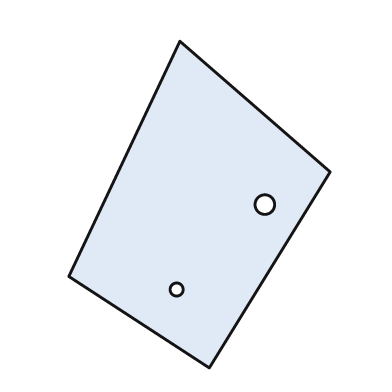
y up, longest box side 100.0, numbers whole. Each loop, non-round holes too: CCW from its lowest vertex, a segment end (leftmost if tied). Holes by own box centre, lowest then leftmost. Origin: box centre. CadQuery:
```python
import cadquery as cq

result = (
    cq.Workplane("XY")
    .moveTo(3.0, -50.0)
    .lineTo(40.0, 10.0)
    .lineTo(-6.0, 50.0)
    .lineTo(-40.0, -22.0)
    .close()
    .moveTo(-7.0, -26.0)
    .circle(2.0)
    .moveTo(20.0, 0.0)
    .circle(3.0)
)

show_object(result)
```